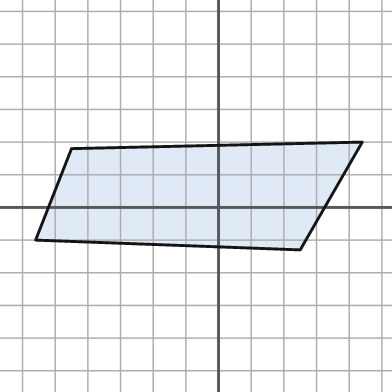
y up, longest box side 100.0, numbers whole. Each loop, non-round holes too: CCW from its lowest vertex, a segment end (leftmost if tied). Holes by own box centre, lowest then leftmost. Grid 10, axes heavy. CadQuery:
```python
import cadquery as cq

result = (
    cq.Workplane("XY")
    .moveTo(25.0, -13.0)
    .lineTo(44.0, 20.0)
    .lineTo(-45.0, 18.0)
    .lineTo(-56.0, -10.0)
    .close()
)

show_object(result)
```